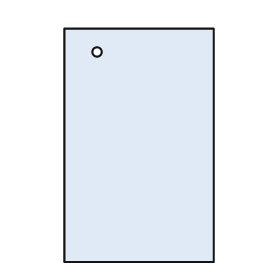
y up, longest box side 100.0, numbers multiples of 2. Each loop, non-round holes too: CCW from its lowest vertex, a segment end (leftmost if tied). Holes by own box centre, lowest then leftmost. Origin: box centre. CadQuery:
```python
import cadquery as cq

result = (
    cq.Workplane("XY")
    .moveTo(-32.0, -50.0)
    .lineTo(32.0, -50.0)
    .lineTo(32.0, 50.0)
    .lineTo(-32.0, 50.0)
    .close()
    .moveTo(-18.0, 40.0)
    .circle(2.0)
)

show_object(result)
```